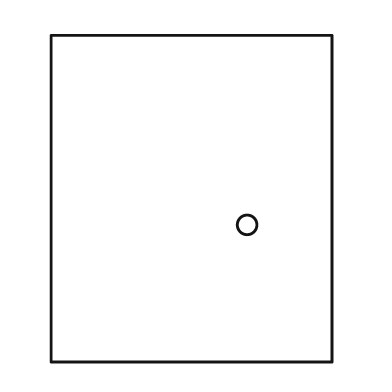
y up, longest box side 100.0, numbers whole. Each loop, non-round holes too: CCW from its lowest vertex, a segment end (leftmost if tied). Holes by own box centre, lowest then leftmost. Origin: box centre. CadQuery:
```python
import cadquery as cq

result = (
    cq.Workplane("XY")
    .moveTo(-43.0, -50.0)
    .lineTo(43.0, -50.0)
    .lineTo(43.0, 50.0)
    .lineTo(-43.0, 50.0)
    .close()
    .moveTo(17.0, -8.0)
    .circle(3.0)
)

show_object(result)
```